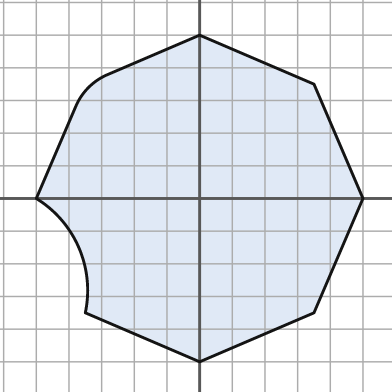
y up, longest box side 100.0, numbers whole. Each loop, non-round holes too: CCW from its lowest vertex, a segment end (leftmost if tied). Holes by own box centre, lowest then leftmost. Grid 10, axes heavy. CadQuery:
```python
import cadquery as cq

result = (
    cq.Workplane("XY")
    .moveTo(0.0, -50.0)
    .lineTo(35.0, -35.0)
    .lineTo(50.0, 0.0)
    .lineTo(35.0, 35.0)
    .lineTo(0.0, 50.0)
    .lineTo(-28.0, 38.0)
    .threePointArc((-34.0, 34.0), (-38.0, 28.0))
    .lineTo(-50.0, 0.0)
    .threePointArc((-37.0, -15.0), (-35.0, -35.0))
    .close()
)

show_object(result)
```